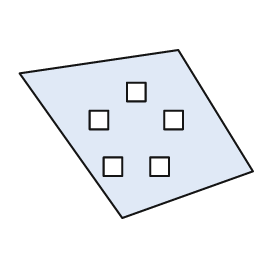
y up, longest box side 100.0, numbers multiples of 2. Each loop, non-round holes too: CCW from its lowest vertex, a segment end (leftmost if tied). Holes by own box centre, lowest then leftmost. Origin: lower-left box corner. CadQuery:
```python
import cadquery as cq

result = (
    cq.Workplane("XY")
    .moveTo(44.0, 0.0)
    .lineTo(100.0, 20.0)
    .lineTo(68.0, 72.0)
    .lineTo(0.0, 62.0)
    .close()
    .moveTo(36.0, 18.0)
    .lineTo(44.0, 18.0)
    .lineTo(44.0, 26.0)
    .lineTo(36.0, 26.0)
    .close()
    .moveTo(56.0, 18.0)
    .lineTo(64.0, 18.0)
    .lineTo(64.0, 26.0)
    .lineTo(56.0, 26.0)
    .close()
    .moveTo(30.0, 38.0)
    .lineTo(38.0, 38.0)
    .lineTo(38.0, 46.0)
    .lineTo(30.0, 46.0)
    .close()
    .moveTo(62.0, 38.0)
    .lineTo(70.0, 38.0)
    .lineTo(70.0, 46.0)
    .lineTo(62.0, 46.0)
    .close()
    .moveTo(46.0, 50.0)
    .lineTo(54.0, 50.0)
    .lineTo(54.0, 58.0)
    .lineTo(46.0, 58.0)
    .close()
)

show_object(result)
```